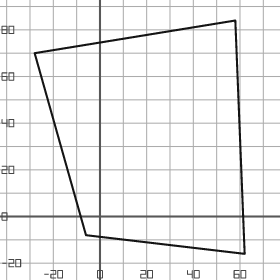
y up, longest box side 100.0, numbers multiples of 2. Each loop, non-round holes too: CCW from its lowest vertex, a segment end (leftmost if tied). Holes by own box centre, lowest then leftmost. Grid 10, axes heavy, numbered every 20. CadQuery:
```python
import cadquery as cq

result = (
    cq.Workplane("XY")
    .moveTo(62.0, -16.0)
    .lineTo(58.0, 84.0)
    .lineTo(-28.0, 70.0)
    .lineTo(-6.0, -8.0)
    .close()
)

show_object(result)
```